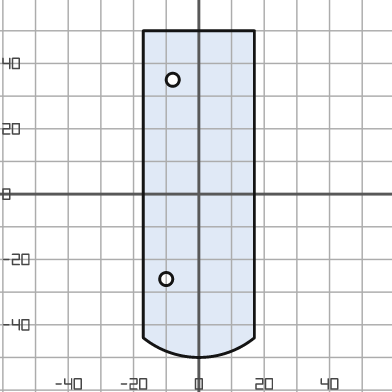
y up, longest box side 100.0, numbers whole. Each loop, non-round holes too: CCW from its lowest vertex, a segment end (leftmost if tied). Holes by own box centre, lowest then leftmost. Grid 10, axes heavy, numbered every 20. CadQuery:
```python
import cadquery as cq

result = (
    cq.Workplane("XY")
    .moveTo(-17.0, -44.0)
    .threePointArc((0.0, -50.0), (17.0, -44.0))
    .lineTo(17.0, 50.0)
    .lineTo(-17.0, 50.0)
    .close()
    .moveTo(-10.0, -26.0)
    .circle(2.0)
    .moveTo(-8.0, 35.0)
    .circle(2.0)
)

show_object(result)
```